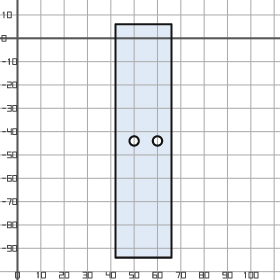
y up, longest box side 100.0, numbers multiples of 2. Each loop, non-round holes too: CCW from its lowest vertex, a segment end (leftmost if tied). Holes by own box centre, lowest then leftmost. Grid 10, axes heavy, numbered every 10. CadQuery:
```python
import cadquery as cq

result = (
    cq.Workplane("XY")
    .moveTo(42.0, -94.0)
    .lineTo(66.0, -94.0)
    .lineTo(66.0, 6.0)
    .lineTo(42.0, 6.0)
    .close()
    .moveTo(50.0, -44.0)
    .circle(2.0)
    .moveTo(60.0, -44.0)
    .circle(2.0)
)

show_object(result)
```